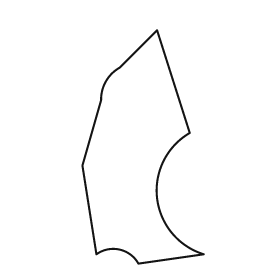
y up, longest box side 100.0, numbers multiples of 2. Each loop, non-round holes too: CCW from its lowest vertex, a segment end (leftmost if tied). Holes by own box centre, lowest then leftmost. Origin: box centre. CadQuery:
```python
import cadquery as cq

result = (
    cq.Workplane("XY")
    .moveTo(-2.0, -50.0)
    .lineTo(26.0, -46.0)
    .threePointArc((6.0, -22.0), (20.0, 6.0))
    .lineTo(6.0, 50.0)
    .lineTo(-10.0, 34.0)
    .threePointArc((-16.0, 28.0), (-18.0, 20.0))
    .lineTo(-26.0, -8.0)
    .lineTo(-20.0, -46.0)
    .threePointArc((-10.0, -44.0), (-2.0, -50.0))
    .close()
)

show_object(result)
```